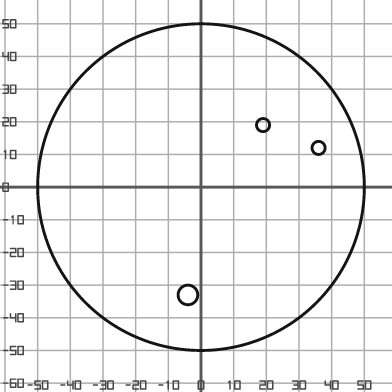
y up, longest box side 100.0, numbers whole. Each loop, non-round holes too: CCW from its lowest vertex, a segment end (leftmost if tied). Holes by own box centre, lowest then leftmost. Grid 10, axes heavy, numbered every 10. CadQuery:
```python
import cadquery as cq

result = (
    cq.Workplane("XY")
    .moveTo(0.0, 0.0)
    .circle(50.0)
    .moveTo(-4.0, -33.0)
    .circle(3.0)
    .moveTo(36.0, 12.0)
    .circle(2.0)
    .moveTo(19.0, 19.0)
    .circle(2.0)
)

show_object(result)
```